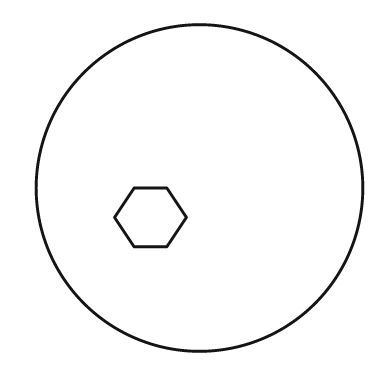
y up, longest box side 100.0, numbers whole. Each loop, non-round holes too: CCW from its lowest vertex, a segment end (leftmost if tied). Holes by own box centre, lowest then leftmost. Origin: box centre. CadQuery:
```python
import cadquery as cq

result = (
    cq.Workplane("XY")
    .moveTo(0.0, 0.0)
    .circle(50.0)
    .moveTo(-20.0, -18.0)
    .lineTo(-10.0, -18.0)
    .lineTo(-4.0, -9.0)
    .lineTo(-10.0, 0.0)
    .lineTo(-20.0, 0.0)
    .lineTo(-26.0, -9.0)
    .close()
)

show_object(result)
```